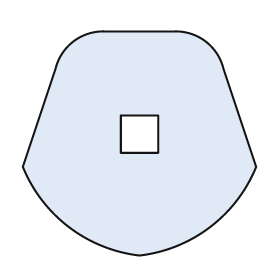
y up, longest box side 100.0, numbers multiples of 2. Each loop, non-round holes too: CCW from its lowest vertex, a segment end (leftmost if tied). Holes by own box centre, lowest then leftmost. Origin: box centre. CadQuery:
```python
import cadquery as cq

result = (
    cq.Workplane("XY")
    .moveTo(0.0, -48.0)
    .threePointArc((30.0, -36.0), (50.0, -10.0))
    .lineTo(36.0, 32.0)
    .threePointArc((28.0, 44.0), (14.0, 48.0))
    .lineTo(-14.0, 48.0)
    .threePointArc((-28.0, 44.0), (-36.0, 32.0))
    .lineTo(-50.0, -10.0)
    .threePointArc((-30.0, -36.0), (0.0, -48.0))
    .close()
    .moveTo(-8.0, -4.0)
    .lineTo(8.0, -4.0)
    .lineTo(8.0, 12.0)
    .lineTo(-8.0, 12.0)
    .close()
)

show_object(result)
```